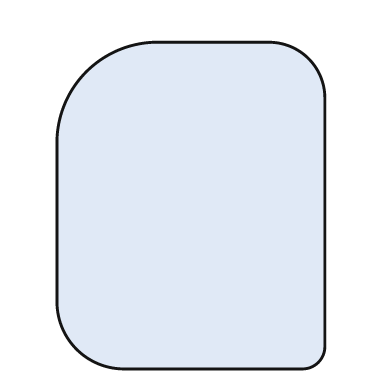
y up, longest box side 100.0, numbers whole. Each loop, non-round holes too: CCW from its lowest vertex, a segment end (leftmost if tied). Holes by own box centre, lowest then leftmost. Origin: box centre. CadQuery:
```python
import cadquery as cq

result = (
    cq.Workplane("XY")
    .moveTo(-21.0, -50.0)
    .lineTo(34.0, -50.0)
    .threePointArc((39.0, -48.0), (41.0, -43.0))
    .lineTo(41.0, 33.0)
    .threePointArc((36.0, 45.0), (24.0, 50.0))
    .lineTo(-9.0, 50.0)
    .threePointArc((-32.0, 41.0), (-41.0, 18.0))
    .lineTo(-41.0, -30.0)
    .threePointArc((-35.0, -44.0), (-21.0, -50.0))
    .close()
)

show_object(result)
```